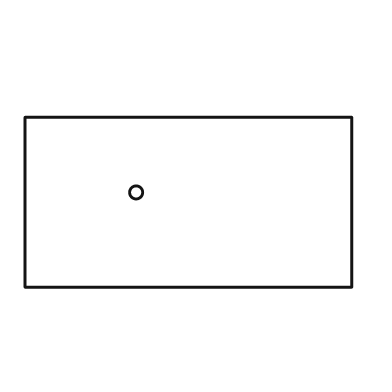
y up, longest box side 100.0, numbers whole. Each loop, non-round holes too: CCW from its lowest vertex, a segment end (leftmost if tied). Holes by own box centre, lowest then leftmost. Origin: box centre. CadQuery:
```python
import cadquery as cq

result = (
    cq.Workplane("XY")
    .moveTo(-50.0, -26.0)
    .lineTo(50.0, -26.0)
    .lineTo(50.0, 26.0)
    .lineTo(-50.0, 26.0)
    .close()
    .moveTo(-16.0, 3.0)
    .circle(2.0)
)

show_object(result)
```